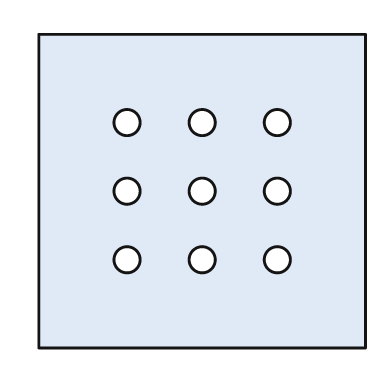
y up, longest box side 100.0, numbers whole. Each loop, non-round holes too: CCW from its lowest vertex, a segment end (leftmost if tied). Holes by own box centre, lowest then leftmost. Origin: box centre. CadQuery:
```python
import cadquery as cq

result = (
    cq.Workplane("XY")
    .moveTo(-50.0, -48.0)
    .lineTo(50.0, -48.0)
    .lineTo(50.0, 48.0)
    .lineTo(-50.0, 48.0)
    .close()
    .moveTo(-23.0, -21.0)
    .circle(4.0)
    .moveTo(0.0, -21.0)
    .circle(4.0)
    .moveTo(23.0, -21.0)
    .circle(4.0)
    .moveTo(-23.0, 0.0)
    .circle(4.0)
    .moveTo(0.0, 0.0)
    .circle(4.0)
    .moveTo(23.0, 0.0)
    .circle(4.0)
    .moveTo(-23.0, 21.0)
    .circle(4.0)
    .moveTo(0.0, 21.0)
    .circle(4.0)
    .moveTo(23.0, 21.0)
    .circle(4.0)
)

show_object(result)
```